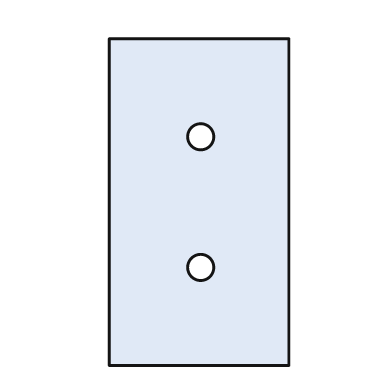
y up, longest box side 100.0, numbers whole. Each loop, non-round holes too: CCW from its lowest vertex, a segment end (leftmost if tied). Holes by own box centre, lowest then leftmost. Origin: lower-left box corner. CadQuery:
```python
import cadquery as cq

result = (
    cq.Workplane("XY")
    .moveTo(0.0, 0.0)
    .lineTo(55.0, 0.0)
    .lineTo(55.0, 100.0)
    .lineTo(0.0, 100.0)
    .close()
    .moveTo(28.0, 30.0)
    .circle(4.0)
    .moveTo(28.0, 70.0)
    .circle(4.0)
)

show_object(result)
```